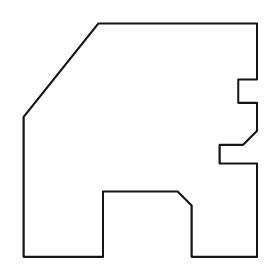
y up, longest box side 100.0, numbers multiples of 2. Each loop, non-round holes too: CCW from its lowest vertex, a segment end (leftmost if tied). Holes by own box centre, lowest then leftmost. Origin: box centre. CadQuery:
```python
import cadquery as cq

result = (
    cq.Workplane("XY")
    .moveTo(-50.0, -50.0)
    .lineTo(-16.0, -50.0)
    .lineTo(-16.0, -22.0)
    .lineTo(16.0, -22.0)
    .lineTo(22.0, -28.0)
    .lineTo(22.0, -50.0)
    .lineTo(50.0, -50.0)
    .lineTo(50.0, -10.0)
    .lineTo(34.0, -10.0)
    .lineTo(34.0, -2.0)
    .lineTo(44.0, -2.0)
    .lineTo(50.0, 4.0)
    .lineTo(50.0, 16.0)
    .lineTo(42.0, 16.0)
    .lineTo(42.0, 26.0)
    .lineTo(50.0, 26.0)
    .lineTo(50.0, 50.0)
    .lineTo(-18.0, 50.0)
    .lineTo(-50.0, 10.0)
    .close()
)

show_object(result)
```